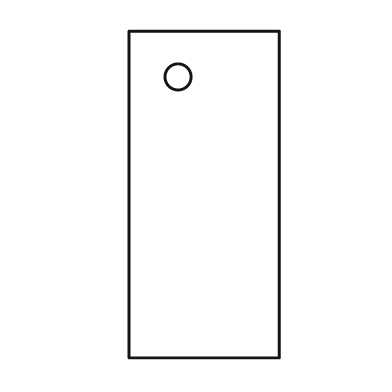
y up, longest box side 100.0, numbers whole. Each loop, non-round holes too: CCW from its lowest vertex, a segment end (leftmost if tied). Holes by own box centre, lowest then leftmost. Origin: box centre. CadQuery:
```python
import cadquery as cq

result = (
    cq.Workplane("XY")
    .moveTo(-23.0, -50.0)
    .lineTo(23.0, -50.0)
    .lineTo(23.0, 50.0)
    .lineTo(-23.0, 50.0)
    .close()
    .moveTo(-8.0, 36.0)
    .circle(4.0)
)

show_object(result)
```